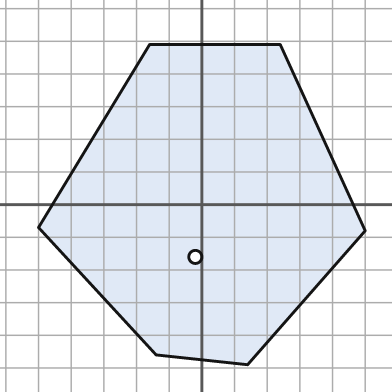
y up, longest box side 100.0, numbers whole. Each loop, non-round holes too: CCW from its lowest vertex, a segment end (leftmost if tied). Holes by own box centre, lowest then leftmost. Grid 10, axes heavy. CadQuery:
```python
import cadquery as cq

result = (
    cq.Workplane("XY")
    .moveTo(14.0, -49.0)
    .lineTo(50.0, -8.0)
    .lineTo(24.0, 49.0)
    .lineTo(-16.0, 49.0)
    .lineTo(-50.0, -7.0)
    .lineTo(-14.0, -46.0)
    .close()
    .moveTo(-2.0, -16.0)
    .circle(2.0)
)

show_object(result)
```